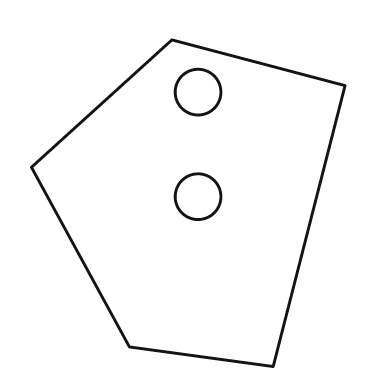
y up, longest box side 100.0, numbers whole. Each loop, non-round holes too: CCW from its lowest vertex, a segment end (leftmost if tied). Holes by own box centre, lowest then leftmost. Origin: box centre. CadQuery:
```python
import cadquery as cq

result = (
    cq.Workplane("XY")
    .moveTo(26.0, -50.0)
    .lineTo(48.0, 36.0)
    .lineTo(-5.0, 50.0)
    .lineTo(-48.0, 11.0)
    .lineTo(-18.0, -44.0)
    .close()
    .moveTo(3.0, 2.0)
    .circle(7.0)
    .moveTo(3.0, 34.0)
    .circle(7.0)
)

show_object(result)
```